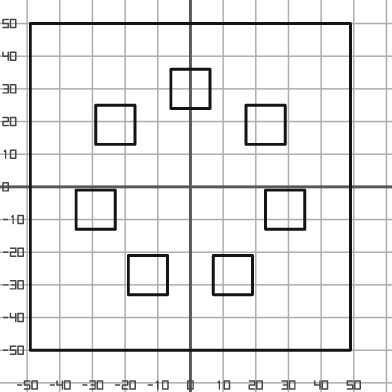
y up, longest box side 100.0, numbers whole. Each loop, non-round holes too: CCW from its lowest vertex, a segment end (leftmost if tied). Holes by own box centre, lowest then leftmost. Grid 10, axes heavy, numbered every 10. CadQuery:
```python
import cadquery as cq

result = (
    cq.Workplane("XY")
    .moveTo(-49.0, -50.0)
    .lineTo(49.0, -50.0)
    .lineTo(49.0, 50.0)
    .lineTo(-49.0, 50.0)
    .close()
    .moveTo(-19.0, -33.0)
    .lineTo(-7.0, -33.0)
    .lineTo(-7.0, -21.0)
    .lineTo(-19.0, -21.0)
    .close()
    .moveTo(7.0, -33.0)
    .lineTo(19.0, -33.0)
    .lineTo(19.0, -21.0)
    .lineTo(7.0, -21.0)
    .close()
    .moveTo(-35.0, -13.0)
    .lineTo(-23.0, -13.0)
    .lineTo(-23.0, -1.0)
    .lineTo(-35.0, -1.0)
    .close()
    .moveTo(23.0, -13.0)
    .lineTo(35.0, -13.0)
    .lineTo(35.0, -1.0)
    .lineTo(23.0, -1.0)
    .close()
    .moveTo(-29.0, 13.0)
    .lineTo(-17.0, 13.0)
    .lineTo(-17.0, 25.0)
    .lineTo(-29.0, 25.0)
    .close()
    .moveTo(17.0, 13.0)
    .lineTo(29.0, 13.0)
    .lineTo(29.0, 25.0)
    .lineTo(17.0, 25.0)
    .close()
    .moveTo(-6.0, 24.0)
    .lineTo(6.0, 24.0)
    .lineTo(6.0, 36.0)
    .lineTo(-6.0, 36.0)
    .close()
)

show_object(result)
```